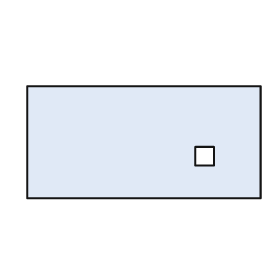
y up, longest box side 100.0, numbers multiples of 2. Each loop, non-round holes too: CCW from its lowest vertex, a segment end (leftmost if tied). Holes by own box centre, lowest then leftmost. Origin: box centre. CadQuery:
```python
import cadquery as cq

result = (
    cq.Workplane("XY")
    .moveTo(-50.0, -24.0)
    .lineTo(50.0, -24.0)
    .lineTo(50.0, 24.0)
    .lineTo(-50.0, 24.0)
    .close()
    .moveTo(22.0, -10.0)
    .lineTo(30.0, -10.0)
    .lineTo(30.0, -2.0)
    .lineTo(22.0, -2.0)
    .close()
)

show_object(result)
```